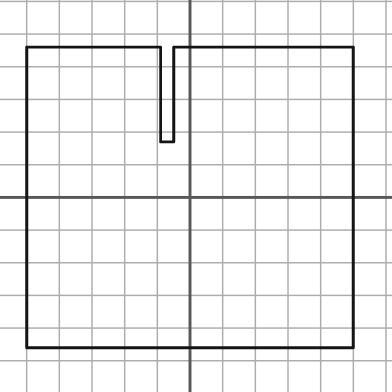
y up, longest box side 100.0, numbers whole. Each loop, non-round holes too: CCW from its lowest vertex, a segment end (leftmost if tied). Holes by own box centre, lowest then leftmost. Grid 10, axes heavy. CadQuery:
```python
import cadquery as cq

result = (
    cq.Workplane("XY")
    .moveTo(-50.0, -46.0)
    .lineTo(50.0, -46.0)
    .lineTo(50.0, 46.0)
    .lineTo(-5.0, 46.0)
    .lineTo(-5.0, 17.0)
    .lineTo(-9.0, 17.0)
    .lineTo(-9.0, 46.0)
    .lineTo(-50.0, 46.0)
    .close()
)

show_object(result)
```